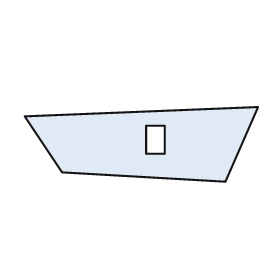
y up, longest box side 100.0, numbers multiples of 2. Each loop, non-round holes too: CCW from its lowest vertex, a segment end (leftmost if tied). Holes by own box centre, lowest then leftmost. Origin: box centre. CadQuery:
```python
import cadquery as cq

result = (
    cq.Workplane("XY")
    .moveTo(36.0, -16.0)
    .lineTo(50.0, 16.0)
    .lineTo(-50.0, 12.0)
    .lineTo(-34.0, -12.0)
    .close()
    .moveTo(2.0, -4.0)
    .lineTo(10.0, -4.0)
    .lineTo(10.0, 8.0)
    .lineTo(2.0, 8.0)
    .close()
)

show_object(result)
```